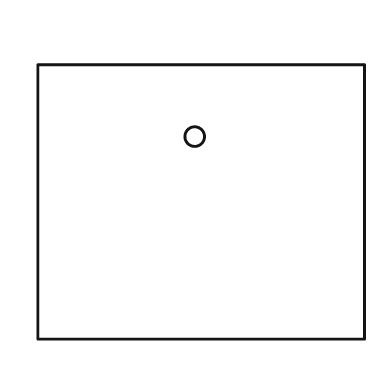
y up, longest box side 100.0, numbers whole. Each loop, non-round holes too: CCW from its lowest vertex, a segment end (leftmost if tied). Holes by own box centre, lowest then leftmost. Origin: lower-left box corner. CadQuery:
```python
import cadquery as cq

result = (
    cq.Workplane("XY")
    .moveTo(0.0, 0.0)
    .lineTo(100.0, 0.0)
    .lineTo(100.0, 84.0)
    .lineTo(0.0, 84.0)
    .close()
    .moveTo(48.0, 62.0)
    .circle(3.0)
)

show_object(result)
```